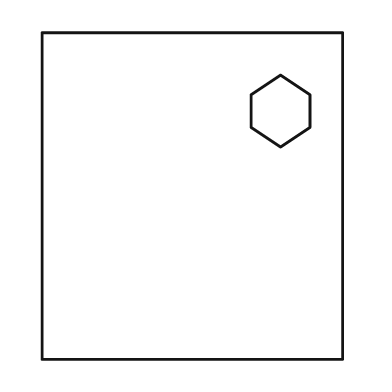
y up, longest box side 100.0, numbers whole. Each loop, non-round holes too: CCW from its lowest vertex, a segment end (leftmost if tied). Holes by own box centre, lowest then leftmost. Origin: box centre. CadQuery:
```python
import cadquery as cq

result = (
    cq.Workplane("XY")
    .moveTo(-46.0, -50.0)
    .lineTo(46.0, -50.0)
    .lineTo(46.0, 50.0)
    .lineTo(-46.0, 50.0)
    .close()
    .moveTo(27.0, 15.0)
    .lineTo(36.0, 21.0)
    .lineTo(36.0, 31.0)
    .lineTo(27.0, 37.0)
    .lineTo(18.0, 31.0)
    .lineTo(18.0, 21.0)
    .close()
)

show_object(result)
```